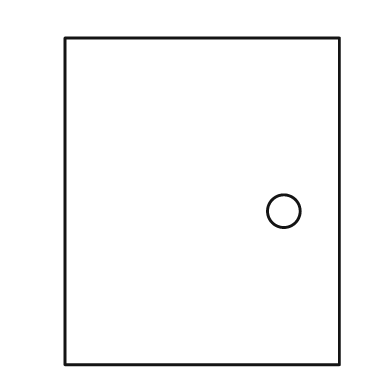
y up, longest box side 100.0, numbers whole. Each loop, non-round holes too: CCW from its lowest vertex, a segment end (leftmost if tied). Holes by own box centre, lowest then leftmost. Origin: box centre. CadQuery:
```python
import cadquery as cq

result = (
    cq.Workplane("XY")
    .moveTo(-42.0, -50.0)
    .lineTo(42.0, -50.0)
    .lineTo(42.0, 50.0)
    .lineTo(-42.0, 50.0)
    .close()
    .moveTo(25.0, -3.0)
    .circle(5.0)
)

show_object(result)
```